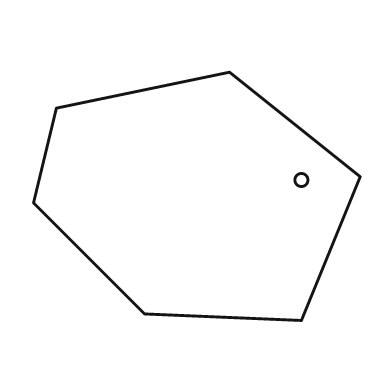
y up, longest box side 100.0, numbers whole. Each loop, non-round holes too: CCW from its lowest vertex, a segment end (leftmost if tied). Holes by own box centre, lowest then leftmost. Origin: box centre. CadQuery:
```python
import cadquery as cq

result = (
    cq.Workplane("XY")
    .moveTo(32.0, -38.0)
    .lineTo(50.0, 6.0)
    .lineTo(10.0, 38.0)
    .lineTo(-43.0, 27.0)
    .lineTo(-50.0, -2.0)
    .lineTo(-16.0, -36.0)
    .close()
    .moveTo(32.0, 5.0)
    .circle(2.0)
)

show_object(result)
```